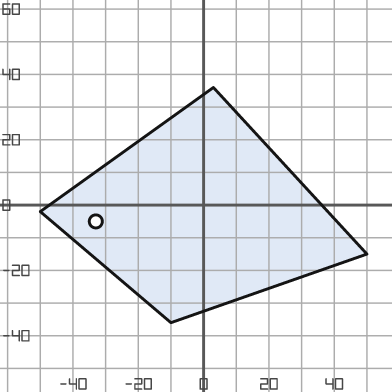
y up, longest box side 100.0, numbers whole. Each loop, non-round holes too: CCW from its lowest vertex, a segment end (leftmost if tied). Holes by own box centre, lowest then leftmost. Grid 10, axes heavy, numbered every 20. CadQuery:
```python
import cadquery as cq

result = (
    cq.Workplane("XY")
    .moveTo(-10.0, -36.0)
    .lineTo(50.0, -15.0)
    .lineTo(3.0, 36.0)
    .lineTo(-50.0, -2.0)
    .close()
    .moveTo(-33.0, -5.0)
    .circle(2.0)
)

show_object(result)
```